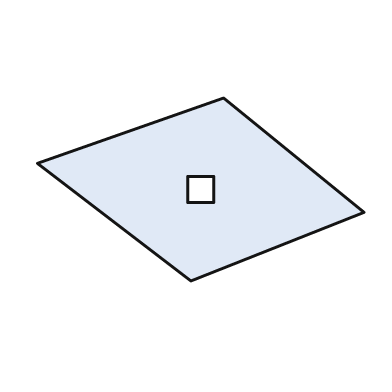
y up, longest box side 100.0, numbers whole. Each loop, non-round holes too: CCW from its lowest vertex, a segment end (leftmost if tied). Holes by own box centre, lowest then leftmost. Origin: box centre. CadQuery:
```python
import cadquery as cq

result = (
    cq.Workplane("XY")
    .moveTo(-3.0, -28.0)
    .lineTo(50.0, -7.0)
    .lineTo(7.0, 28.0)
    .lineTo(-50.0, 8.0)
    .close()
    .moveTo(-4.0, -4.0)
    .lineTo(4.0, -4.0)
    .lineTo(4.0, 4.0)
    .lineTo(-4.0, 4.0)
    .close()
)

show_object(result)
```